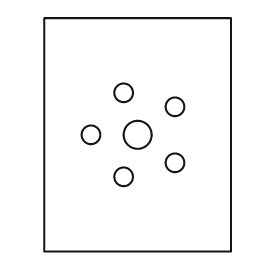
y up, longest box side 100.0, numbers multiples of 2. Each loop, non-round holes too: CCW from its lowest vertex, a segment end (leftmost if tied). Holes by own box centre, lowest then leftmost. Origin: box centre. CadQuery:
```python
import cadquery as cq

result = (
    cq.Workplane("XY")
    .moveTo(-40.0, -50.0)
    .lineTo(40.0, -50.0)
    .lineTo(40.0, 50.0)
    .lineTo(-40.0, 50.0)
    .close()
    .moveTo(-6.0, -18.0)
    .circle(4.0)
    .moveTo(16.0, -12.0)
    .circle(4.0)
    .moveTo(-20.0, 0.0)
    .circle(4.0)
    .moveTo(0.0, 0.0)
    .circle(6.0)
    .moveTo(16.0, 12.0)
    .circle(4.0)
    .moveTo(-6.0, 18.0)
    .circle(4.0)
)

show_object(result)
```